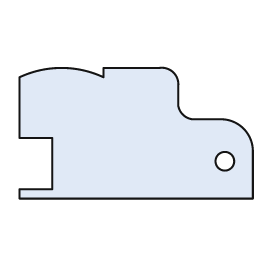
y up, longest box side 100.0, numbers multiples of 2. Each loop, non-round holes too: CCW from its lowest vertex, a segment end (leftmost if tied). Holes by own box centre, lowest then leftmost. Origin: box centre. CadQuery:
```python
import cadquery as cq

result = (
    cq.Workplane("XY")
    .moveTo(-50.0, -28.0)
    .lineTo(50.0, -28.0)
    .lineTo(50.0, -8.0)
    .threePointArc((46.0, 2.0), (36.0, 6.0))
    .lineTo(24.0, 6.0)
    .threePointArc((20.0, 8.0), (18.0, 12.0))
    .lineTo(18.0, 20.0)
    .threePointArc((16.0, 26.0), (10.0, 28.0))
    .lineTo(-14.0, 28.0)
    .lineTo(-14.0, 24.0)
    .threePointArc((-32.0, 28.0), (-50.0, 24.0))
    .lineTo(-50.0, -2.0)
    .lineTo(-36.0, -2.0)
    .lineTo(-36.0, -24.0)
    .lineTo(-50.0, -24.0)
    .close()
    .moveTo(38.0, -12.0)
    .circle(4.0)
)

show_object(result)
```